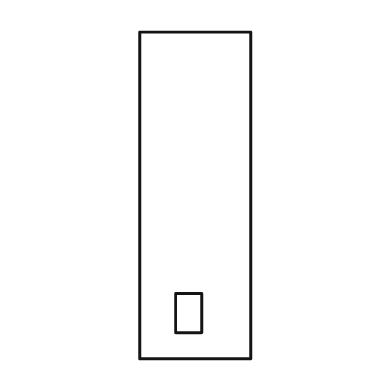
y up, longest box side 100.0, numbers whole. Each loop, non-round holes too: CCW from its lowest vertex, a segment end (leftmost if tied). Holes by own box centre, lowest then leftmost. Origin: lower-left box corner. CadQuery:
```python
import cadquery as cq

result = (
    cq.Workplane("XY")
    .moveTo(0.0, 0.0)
    .lineTo(34.0, 0.0)
    .lineTo(34.0, 100.0)
    .lineTo(0.0, 100.0)
    .close()
    .moveTo(11.0, 8.0)
    .lineTo(19.0, 8.0)
    .lineTo(19.0, 20.0)
    .lineTo(11.0, 20.0)
    .close()
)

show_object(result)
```